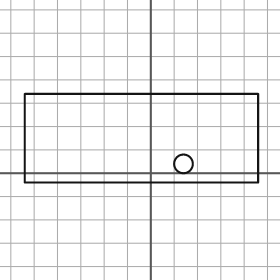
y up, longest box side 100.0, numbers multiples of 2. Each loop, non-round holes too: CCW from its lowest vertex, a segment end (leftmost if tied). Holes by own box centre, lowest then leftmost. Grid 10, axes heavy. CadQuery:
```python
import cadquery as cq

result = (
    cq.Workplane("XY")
    .moveTo(-54.0, -4.0)
    .lineTo(46.0, -4.0)
    .lineTo(46.0, 34.0)
    .lineTo(-54.0, 34.0)
    .close()
    .moveTo(14.0, 4.0)
    .circle(4.0)
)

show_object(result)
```